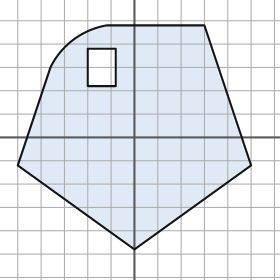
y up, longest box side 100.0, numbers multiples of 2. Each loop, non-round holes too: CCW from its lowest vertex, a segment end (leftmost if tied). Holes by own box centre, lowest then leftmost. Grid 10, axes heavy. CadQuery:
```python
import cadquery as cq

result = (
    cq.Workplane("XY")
    .moveTo(0.0, -48.0)
    .lineTo(50.0, -12.0)
    .lineTo(30.0, 48.0)
    .lineTo(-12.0, 48.0)
    .threePointArc((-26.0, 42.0), (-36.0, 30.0))
    .lineTo(-50.0, -12.0)
    .close()
    .moveTo(-20.0, 22.0)
    .lineTo(-8.0, 22.0)
    .lineTo(-8.0, 38.0)
    .lineTo(-20.0, 38.0)
    .close()
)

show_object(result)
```